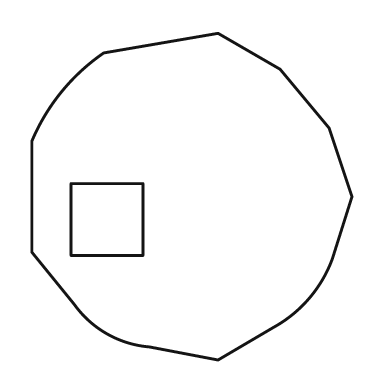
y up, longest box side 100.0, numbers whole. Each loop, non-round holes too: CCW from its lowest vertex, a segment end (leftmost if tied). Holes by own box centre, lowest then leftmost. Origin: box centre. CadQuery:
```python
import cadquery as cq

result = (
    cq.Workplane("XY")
    .moveTo(8.0, -50.0)
    .lineTo(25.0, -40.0)
    .threePointArc((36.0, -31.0), (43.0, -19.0))
    .lineTo(49.0, 0.0)
    .lineTo(42.0, 21.0)
    .lineTo(27.0, 39.0)
    .lineTo(8.0, 50.0)
    .lineTo(-27.0, 44.0)
    .threePointArc((-40.0, 32.0), (-49.0, 17.0))
    .lineTo(-49.0, -17.0)
    .lineTo(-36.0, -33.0)
    .threePointArc((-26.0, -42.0), (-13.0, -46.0))
    .close()
    .moveTo(-37.0, -18.0)
    .lineTo(-15.0, -18.0)
    .lineTo(-15.0, 4.0)
    .lineTo(-37.0, 4.0)
    .close()
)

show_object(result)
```